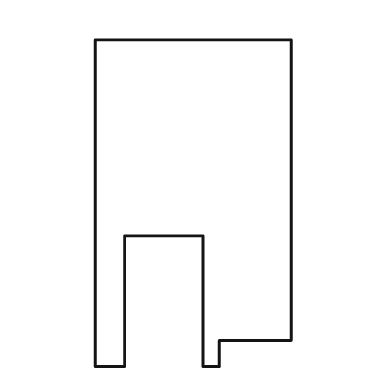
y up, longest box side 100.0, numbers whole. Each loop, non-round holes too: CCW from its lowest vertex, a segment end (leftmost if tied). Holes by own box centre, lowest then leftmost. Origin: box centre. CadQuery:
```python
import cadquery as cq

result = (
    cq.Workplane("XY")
    .moveTo(-30.0, -50.0)
    .lineTo(-21.0, -50.0)
    .lineTo(-21.0, -10.0)
    .lineTo(3.0, -10.0)
    .lineTo(3.0, -50.0)
    .lineTo(8.0, -50.0)
    .lineTo(8.0, -42.0)
    .lineTo(30.0, -42.0)
    .lineTo(30.0, 50.0)
    .lineTo(-30.0, 50.0)
    .close()
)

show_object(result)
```